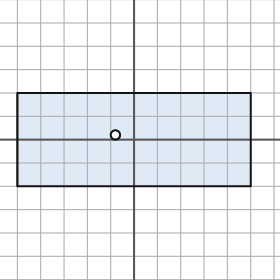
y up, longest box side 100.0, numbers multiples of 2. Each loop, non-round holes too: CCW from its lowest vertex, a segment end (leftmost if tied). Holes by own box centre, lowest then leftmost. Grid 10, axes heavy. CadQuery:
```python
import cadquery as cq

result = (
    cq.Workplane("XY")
    .moveTo(-50.0, -20.0)
    .lineTo(50.0, -20.0)
    .lineTo(50.0, 20.0)
    .lineTo(-50.0, 20.0)
    .close()
    .moveTo(-8.0, 2.0)
    .circle(2.0)
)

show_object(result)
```